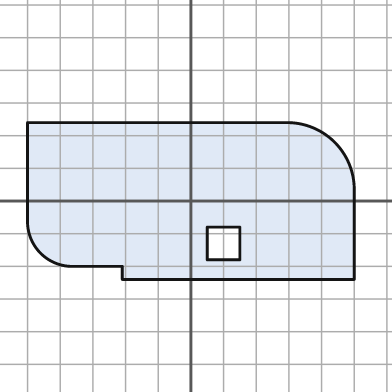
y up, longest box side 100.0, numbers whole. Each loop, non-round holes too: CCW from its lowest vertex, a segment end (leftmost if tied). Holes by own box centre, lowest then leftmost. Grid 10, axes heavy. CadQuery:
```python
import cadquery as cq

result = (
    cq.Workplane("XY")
    .moveTo(-21.0, -24.0)
    .lineTo(50.0, -24.0)
    .lineTo(50.0, 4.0)
    .threePointArc((44.0, 18.0), (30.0, 24.0))
    .lineTo(-50.0, 24.0)
    .lineTo(-50.0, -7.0)
    .threePointArc((-46.0, -16.0), (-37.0, -20.0))
    .lineTo(-21.0, -20.0)
    .close()
    .moveTo(5.0, -18.0)
    .lineTo(15.0, -18.0)
    .lineTo(15.0, -8.0)
    .lineTo(5.0, -8.0)
    .close()
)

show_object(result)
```